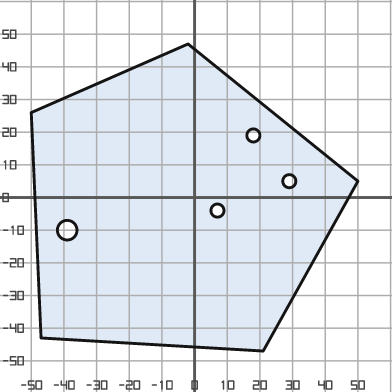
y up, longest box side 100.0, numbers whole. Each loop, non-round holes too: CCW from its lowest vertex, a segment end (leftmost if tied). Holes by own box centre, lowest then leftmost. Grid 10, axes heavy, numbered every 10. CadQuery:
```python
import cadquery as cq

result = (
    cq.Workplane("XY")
    .moveTo(21.0, -47.0)
    .lineTo(50.0, 5.0)
    .lineTo(-2.0, 47.0)
    .lineTo(-50.0, 26.0)
    .lineTo(-47.0, -43.0)
    .close()
    .moveTo(-39.0, -10.0)
    .circle(3.0)
    .moveTo(7.0, -4.0)
    .circle(2.0)
    .moveTo(29.0, 5.0)
    .circle(2.0)
    .moveTo(18.0, 19.0)
    .circle(2.0)
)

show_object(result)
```